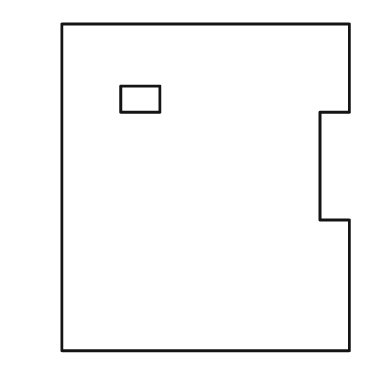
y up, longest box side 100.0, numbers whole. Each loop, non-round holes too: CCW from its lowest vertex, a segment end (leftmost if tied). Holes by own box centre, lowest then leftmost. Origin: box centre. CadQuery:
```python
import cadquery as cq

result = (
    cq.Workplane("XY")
    .moveTo(-44.0, -50.0)
    .lineTo(44.0, -50.0)
    .lineTo(44.0, -10.0)
    .lineTo(35.0, -10.0)
    .lineTo(35.0, 23.0)
    .lineTo(44.0, 23.0)
    .lineTo(44.0, 50.0)
    .lineTo(-44.0, 50.0)
    .close()
    .moveTo(-26.0, 23.0)
    .lineTo(-14.0, 23.0)
    .lineTo(-14.0, 31.0)
    .lineTo(-26.0, 31.0)
    .close()
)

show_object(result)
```